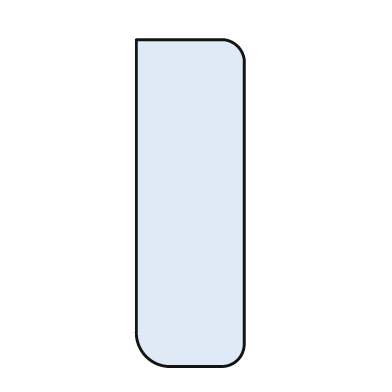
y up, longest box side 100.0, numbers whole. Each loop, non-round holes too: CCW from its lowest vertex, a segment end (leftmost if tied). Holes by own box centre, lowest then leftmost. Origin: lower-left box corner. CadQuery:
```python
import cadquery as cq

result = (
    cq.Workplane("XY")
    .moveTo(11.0, 0.0)
    .lineTo(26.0, 0.0)
    .threePointArc((31.0, 2.0), (33.0, 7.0))
    .lineTo(33.0, 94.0)
    .threePointArc((31.0, 98.0), (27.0, 100.0))
    .lineTo(0.0, 100.0)
    .lineTo(0.0, 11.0)
    .threePointArc((3.0, 3.0), (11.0, 0.0))
    .close()
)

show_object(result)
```